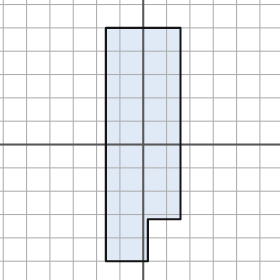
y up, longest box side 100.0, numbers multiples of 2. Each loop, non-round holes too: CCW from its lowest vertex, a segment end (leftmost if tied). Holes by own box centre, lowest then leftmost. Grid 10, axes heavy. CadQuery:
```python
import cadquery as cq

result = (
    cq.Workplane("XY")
    .moveTo(-16.0, -50.0)
    .lineTo(2.0, -50.0)
    .lineTo(2.0, -32.0)
    .lineTo(16.0, -32.0)
    .lineTo(16.0, 50.0)
    .lineTo(-16.0, 50.0)
    .close()
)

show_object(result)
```